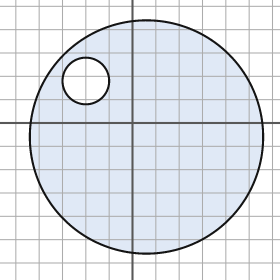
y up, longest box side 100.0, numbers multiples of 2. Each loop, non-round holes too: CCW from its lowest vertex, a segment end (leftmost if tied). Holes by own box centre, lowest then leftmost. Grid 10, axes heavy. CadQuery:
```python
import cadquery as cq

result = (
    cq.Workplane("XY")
    .moveTo(6.0, -6.0)
    .circle(50.0)
    .moveTo(-20.0, 18.0)
    .circle(10.0)
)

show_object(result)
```